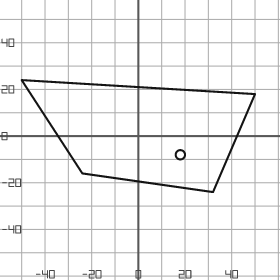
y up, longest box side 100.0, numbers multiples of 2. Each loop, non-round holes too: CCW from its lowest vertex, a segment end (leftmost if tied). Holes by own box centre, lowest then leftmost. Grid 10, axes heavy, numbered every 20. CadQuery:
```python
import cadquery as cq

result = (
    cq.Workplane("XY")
    .moveTo(32.0, -24.0)
    .lineTo(50.0, 18.0)
    .lineTo(-50.0, 24.0)
    .lineTo(-24.0, -16.0)
    .close()
    .moveTo(18.0, -8.0)
    .circle(2.0)
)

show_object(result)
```